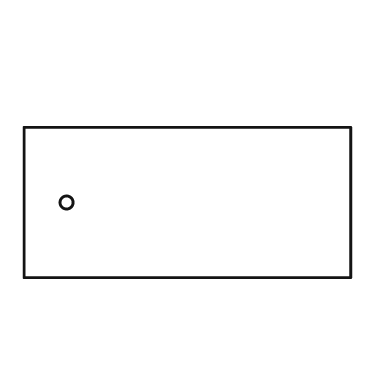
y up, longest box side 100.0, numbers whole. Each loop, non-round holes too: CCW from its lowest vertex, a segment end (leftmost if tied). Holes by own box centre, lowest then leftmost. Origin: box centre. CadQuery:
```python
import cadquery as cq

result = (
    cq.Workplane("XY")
    .moveTo(-50.0, -23.0)
    .lineTo(50.0, -23.0)
    .lineTo(50.0, 23.0)
    .lineTo(-50.0, 23.0)
    .close()
    .moveTo(-37.0, 0.0)
    .circle(2.0)
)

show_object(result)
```